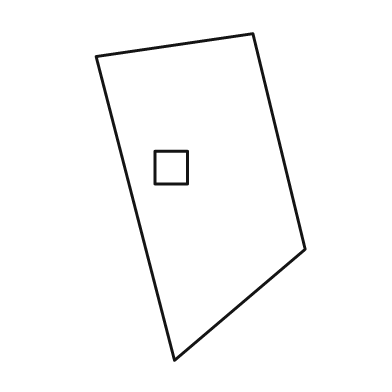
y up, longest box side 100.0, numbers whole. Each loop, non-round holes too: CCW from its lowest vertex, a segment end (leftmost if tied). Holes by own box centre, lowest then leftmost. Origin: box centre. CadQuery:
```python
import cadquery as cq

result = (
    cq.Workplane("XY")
    .moveTo(-8.0, -50.0)
    .lineTo(32.0, -16.0)
    .lineTo(16.0, 50.0)
    .lineTo(-32.0, 43.0)
    .close()
    .moveTo(-14.0, 4.0)
    .lineTo(-4.0, 4.0)
    .lineTo(-4.0, 14.0)
    .lineTo(-14.0, 14.0)
    .close()
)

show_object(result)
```